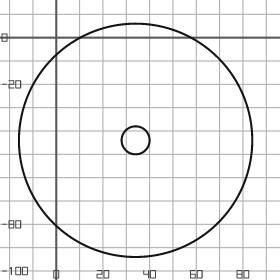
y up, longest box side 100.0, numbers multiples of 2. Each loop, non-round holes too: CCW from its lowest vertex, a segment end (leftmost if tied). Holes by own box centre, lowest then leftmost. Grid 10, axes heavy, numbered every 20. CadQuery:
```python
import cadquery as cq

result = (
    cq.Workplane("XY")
    .moveTo(34.0, -44.0)
    .circle(50.0)
    .moveTo(34.0, -44.0)
    .circle(6.0)
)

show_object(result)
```